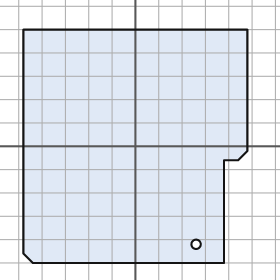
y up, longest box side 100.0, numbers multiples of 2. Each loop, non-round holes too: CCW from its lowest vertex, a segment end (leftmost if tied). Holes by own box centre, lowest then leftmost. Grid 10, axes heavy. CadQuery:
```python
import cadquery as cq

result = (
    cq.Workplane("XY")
    .moveTo(-44.0, -50.0)
    .lineTo(38.0, -50.0)
    .lineTo(38.0, -6.0)
    .lineTo(44.0, -6.0)
    .lineTo(48.0, -2.0)
    .lineTo(48.0, 50.0)
    .lineTo(-48.0, 50.0)
    .lineTo(-48.0, -46.0)
    .close()
    .moveTo(26.0, -42.0)
    .circle(2.0)
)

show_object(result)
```